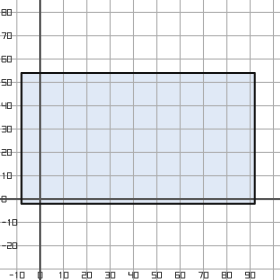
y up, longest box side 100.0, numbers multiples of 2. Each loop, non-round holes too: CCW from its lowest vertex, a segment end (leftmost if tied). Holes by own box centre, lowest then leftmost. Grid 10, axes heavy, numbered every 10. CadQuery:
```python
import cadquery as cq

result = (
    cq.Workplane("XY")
    .moveTo(-8.0, -2.0)
    .lineTo(92.0, -2.0)
    .lineTo(92.0, 54.0)
    .lineTo(-8.0, 54.0)
    .close()
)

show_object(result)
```